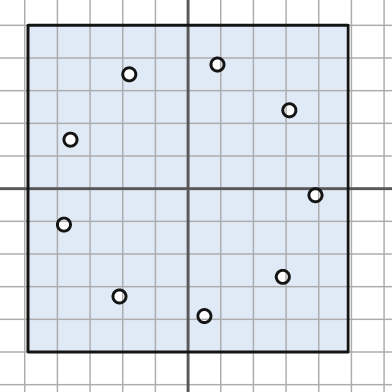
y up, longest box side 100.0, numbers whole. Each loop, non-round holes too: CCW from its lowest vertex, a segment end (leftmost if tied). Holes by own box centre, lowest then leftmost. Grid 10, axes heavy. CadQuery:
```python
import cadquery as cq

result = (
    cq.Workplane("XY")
    .moveTo(-49.0, -50.0)
    .lineTo(49.0, -50.0)
    .lineTo(49.0, 50.0)
    .lineTo(-49.0, 50.0)
    .close()
    .moveTo(5.0, -39.0)
    .circle(2.0)
    .moveTo(-21.0, -33.0)
    .circle(2.0)
    .moveTo(29.0, -27.0)
    .circle(2.0)
    .moveTo(-38.0, -11.0)
    .circle(2.0)
    .moveTo(39.0, -2.0)
    .circle(2.0)
    .moveTo(-36.0, 15.0)
    .circle(2.0)
    .moveTo(31.0, 24.0)
    .circle(2.0)
    .moveTo(-18.0, 35.0)
    .circle(2.0)
    .moveTo(9.0, 38.0)
    .circle(2.0)
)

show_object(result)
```